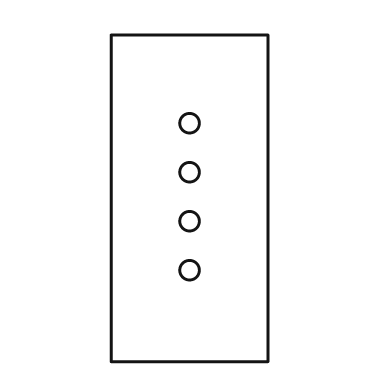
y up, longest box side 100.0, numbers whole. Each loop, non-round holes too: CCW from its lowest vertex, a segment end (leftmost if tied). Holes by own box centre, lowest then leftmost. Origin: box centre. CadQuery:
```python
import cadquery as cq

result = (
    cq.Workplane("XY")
    .moveTo(-24.0, -50.0)
    .lineTo(24.0, -50.0)
    .lineTo(24.0, 50.0)
    .lineTo(-24.0, 50.0)
    .close()
    .moveTo(0.0, -22.0)
    .circle(3.0)
    .moveTo(0.0, -7.0)
    .circle(3.0)
    .moveTo(0.0, 8.0)
    .circle(3.0)
    .moveTo(0.0, 23.0)
    .circle(3.0)
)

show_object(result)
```